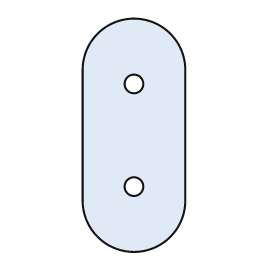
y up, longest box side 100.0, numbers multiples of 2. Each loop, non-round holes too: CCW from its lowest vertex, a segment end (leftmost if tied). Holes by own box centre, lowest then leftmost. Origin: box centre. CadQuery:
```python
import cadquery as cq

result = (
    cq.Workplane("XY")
    .moveTo(-22.0, -28.0)
    .threePointArc((0.0, -50.0), (22.0, -28.0))
    .lineTo(22.0, 28.0)
    .threePointArc((0.0, 50.0), (-22.0, 28.0))
    .close()
    .moveTo(0.0, -22.0)
    .circle(4.0)
    .moveTo(0.0, 22.0)
    .circle(4.0)
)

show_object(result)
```